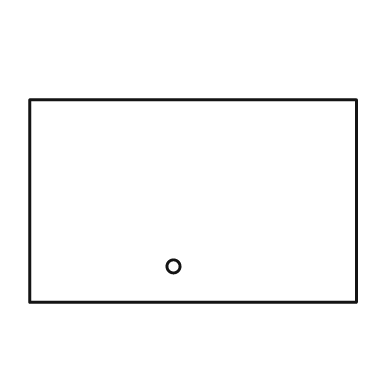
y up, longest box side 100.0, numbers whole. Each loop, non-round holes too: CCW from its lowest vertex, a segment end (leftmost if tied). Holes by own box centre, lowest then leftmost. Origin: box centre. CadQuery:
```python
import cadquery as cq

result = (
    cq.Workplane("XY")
    .moveTo(-50.0, -31.0)
    .lineTo(50.0, -31.0)
    .lineTo(50.0, 31.0)
    .lineTo(-50.0, 31.0)
    .close()
    .moveTo(-6.0, -20.0)
    .circle(2.0)
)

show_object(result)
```